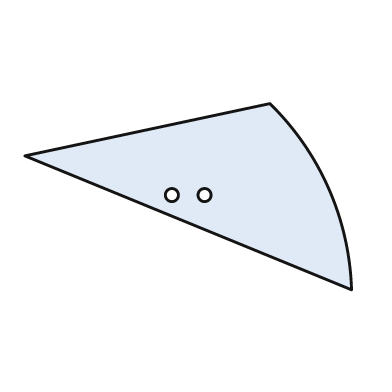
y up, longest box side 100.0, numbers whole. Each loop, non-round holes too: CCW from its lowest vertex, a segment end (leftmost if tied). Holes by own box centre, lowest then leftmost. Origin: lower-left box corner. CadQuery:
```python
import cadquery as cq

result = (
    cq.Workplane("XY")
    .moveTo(100.0, 0.0)
    .threePointArc((93.0, 31.0), (75.0, 57.0))
    .lineTo(0.0, 41.0)
    .close()
    .moveTo(45.0, 29.0)
    .circle(2.0)
    .moveTo(55.0, 29.0)
    .circle(2.0)
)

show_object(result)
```